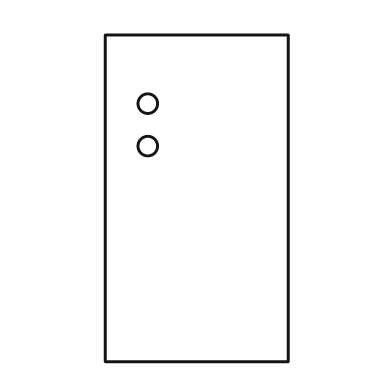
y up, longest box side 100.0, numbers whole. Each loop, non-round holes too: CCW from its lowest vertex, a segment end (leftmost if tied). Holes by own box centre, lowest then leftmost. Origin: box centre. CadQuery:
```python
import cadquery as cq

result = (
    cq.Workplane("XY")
    .moveTo(-28.0, -50.0)
    .lineTo(28.0, -50.0)
    .lineTo(28.0, 50.0)
    .lineTo(-28.0, 50.0)
    .close()
    .moveTo(-15.0, 16.0)
    .circle(3.0)
    .moveTo(-15.0, 29.0)
    .circle(3.0)
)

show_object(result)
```